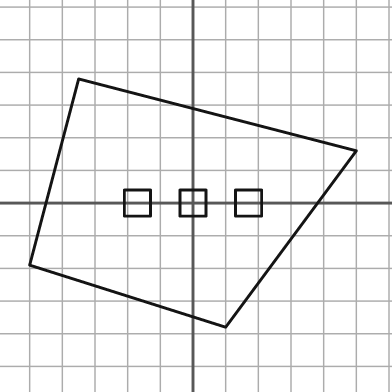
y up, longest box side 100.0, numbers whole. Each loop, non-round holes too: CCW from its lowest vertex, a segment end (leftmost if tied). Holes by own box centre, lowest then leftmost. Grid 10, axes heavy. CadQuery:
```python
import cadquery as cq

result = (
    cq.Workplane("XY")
    .moveTo(10.0, -38.0)
    .lineTo(50.0, 16.0)
    .lineTo(-35.0, 38.0)
    .lineTo(-50.0, -19.0)
    .close()
    .moveTo(-21.0, -4.0)
    .lineTo(-13.0, -4.0)
    .lineTo(-13.0, 4.0)
    .lineTo(-21.0, 4.0)
    .close()
    .moveTo(-4.0, -4.0)
    .lineTo(4.0, -4.0)
    .lineTo(4.0, 4.0)
    .lineTo(-4.0, 4.0)
    .close()
    .moveTo(13.0, -4.0)
    .lineTo(21.0, -4.0)
    .lineTo(21.0, 4.0)
    .lineTo(13.0, 4.0)
    .close()
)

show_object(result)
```